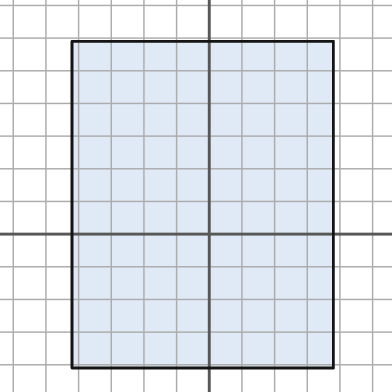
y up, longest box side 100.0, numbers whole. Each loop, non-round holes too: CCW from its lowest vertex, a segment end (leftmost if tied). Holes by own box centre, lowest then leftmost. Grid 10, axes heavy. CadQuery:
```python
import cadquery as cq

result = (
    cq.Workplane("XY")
    .moveTo(-42.0, -41.0)
    .lineTo(38.0, -41.0)
    .lineTo(38.0, 59.0)
    .lineTo(-42.0, 59.0)
    .close()
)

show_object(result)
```